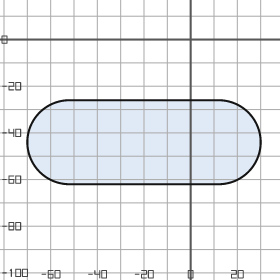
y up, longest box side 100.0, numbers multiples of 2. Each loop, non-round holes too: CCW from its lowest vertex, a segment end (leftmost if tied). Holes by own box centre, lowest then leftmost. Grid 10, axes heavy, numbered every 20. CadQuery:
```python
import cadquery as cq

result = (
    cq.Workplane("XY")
    .moveTo(-52.0, -62.0)
    .lineTo(12.0, -62.0)
    .threePointArc((30.0, -44.0), (12.0, -26.0))
    .lineTo(-52.0, -26.0)
    .threePointArc((-70.0, -44.0), (-52.0, -62.0))
    .close()
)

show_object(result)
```